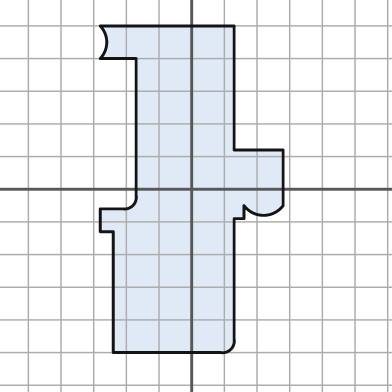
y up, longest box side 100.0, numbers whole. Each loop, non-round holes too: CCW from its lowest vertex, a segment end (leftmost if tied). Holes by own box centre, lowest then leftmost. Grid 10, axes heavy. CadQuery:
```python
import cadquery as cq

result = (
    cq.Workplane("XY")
    .moveTo(-24.0, -50.0)
    .lineTo(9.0, -50.0)
    .threePointArc((12.0, -49.0), (13.0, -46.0))
    .lineTo(13.0, -9.0)
    .lineTo(16.0, -9.0)
    .lineTo(16.0, -5.0)
    .threePointArc((22.0, -8.0), (28.0, -5.0))
    .lineTo(28.0, 12.0)
    .lineTo(13.0, 12.0)
    .lineTo(13.0, 50.0)
    .lineTo(-28.0, 50.0)
    .threePointArc((-26.0, 45.0), (-28.0, 40.0))
    .lineTo(-17.0, 40.0)
    .lineTo(-17.0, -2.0)
    .threePointArc((-18.0, -5.0), (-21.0, -6.0))
    .lineTo(-28.0, -6.0)
    .lineTo(-28.0, -13.0)
    .lineTo(-24.0, -13.0)
    .close()
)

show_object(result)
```